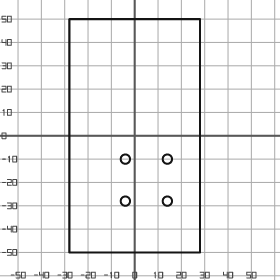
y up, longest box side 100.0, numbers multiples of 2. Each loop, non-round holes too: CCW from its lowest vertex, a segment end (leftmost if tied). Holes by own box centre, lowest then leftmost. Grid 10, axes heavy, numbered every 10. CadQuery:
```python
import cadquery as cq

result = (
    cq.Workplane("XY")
    .moveTo(-28.0, -50.0)
    .lineTo(28.0, -50.0)
    .lineTo(28.0, 50.0)
    .lineTo(-28.0, 50.0)
    .close()
    .moveTo(-4.0, -28.0)
    .circle(2.0)
    .moveTo(14.0, -28.0)
    .circle(2.0)
    .moveTo(-4.0, -10.0)
    .circle(2.0)
    .moveTo(14.0, -10.0)
    .circle(2.0)
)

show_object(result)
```